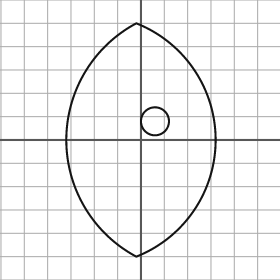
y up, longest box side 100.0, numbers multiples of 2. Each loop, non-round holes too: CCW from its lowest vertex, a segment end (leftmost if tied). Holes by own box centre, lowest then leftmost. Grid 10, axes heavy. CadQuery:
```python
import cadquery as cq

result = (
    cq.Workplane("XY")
    .moveTo(-2.0, -50.0)
    .threePointArc((32.0, 0.0), (-2.0, 50.0))
    .threePointArc((-32.0, 0.0), (-2.0, -50.0))
    .close()
    .moveTo(6.0, 8.0)
    .circle(6.0)
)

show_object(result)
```